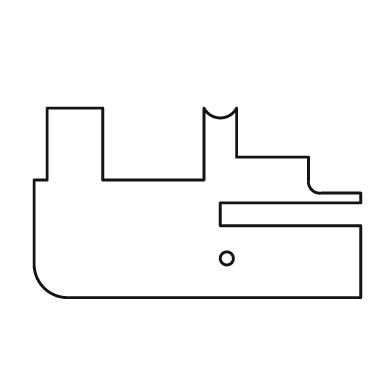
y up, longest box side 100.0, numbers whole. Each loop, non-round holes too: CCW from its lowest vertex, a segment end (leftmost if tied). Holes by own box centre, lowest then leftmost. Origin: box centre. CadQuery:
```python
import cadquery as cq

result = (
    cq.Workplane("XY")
    .moveTo(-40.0, -29.0)
    .lineTo(50.0, -29.0)
    .lineTo(50.0, -7.0)
    .lineTo(7.0, -7.0)
    .lineTo(7.0, 0.0)
    .lineTo(50.0, 0.0)
    .lineTo(50.0, 3.0)
    .lineTo(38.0, 3.0)
    .threePointArc((35.0, 4.0), (34.0, 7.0))
    .lineTo(34.0, 14.0)
    .lineTo(12.0, 14.0)
    .lineTo(12.0, 29.0)
    .threePointArc((7.0, 26.0), (2.0, 29.0))
    .lineTo(2.0, 7.0)
    .lineTo(-29.0, 7.0)
    .lineTo(-29.0, 29.0)
    .lineTo(-46.0, 29.0)
    .lineTo(-46.0, 7.0)
    .lineTo(-50.0, 7.0)
    .lineTo(-50.0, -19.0)
    .threePointArc((-47.0, -26.0), (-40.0, -29.0))
    .close()
    .moveTo(9.0, -17.0)
    .circle(2.0)
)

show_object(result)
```